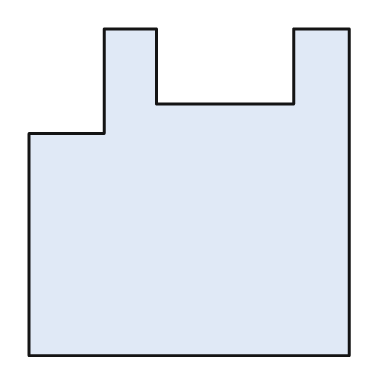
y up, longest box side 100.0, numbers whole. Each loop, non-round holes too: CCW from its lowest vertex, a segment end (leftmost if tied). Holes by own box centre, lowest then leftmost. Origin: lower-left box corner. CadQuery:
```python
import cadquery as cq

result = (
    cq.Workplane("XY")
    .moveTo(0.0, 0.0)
    .lineTo(98.0, 0.0)
    .lineTo(98.0, 100.0)
    .lineTo(81.0, 100.0)
    .lineTo(81.0, 77.0)
    .lineTo(39.0, 77.0)
    .lineTo(39.0, 100.0)
    .lineTo(23.0, 100.0)
    .lineTo(23.0, 68.0)
    .lineTo(0.0, 68.0)
    .close()
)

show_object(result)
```